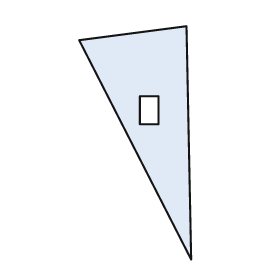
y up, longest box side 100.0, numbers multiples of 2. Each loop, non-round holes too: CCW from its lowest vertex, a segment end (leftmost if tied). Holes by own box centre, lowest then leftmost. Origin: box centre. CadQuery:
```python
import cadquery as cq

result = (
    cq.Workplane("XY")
    .moveTo(24.0, -50.0)
    .lineTo(22.0, 50.0)
    .lineTo(-24.0, 44.0)
    .close()
    .moveTo(2.0, 8.0)
    .lineTo(10.0, 8.0)
    .lineTo(10.0, 20.0)
    .lineTo(2.0, 20.0)
    .close()
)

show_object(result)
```